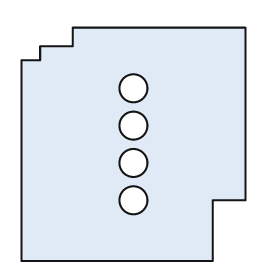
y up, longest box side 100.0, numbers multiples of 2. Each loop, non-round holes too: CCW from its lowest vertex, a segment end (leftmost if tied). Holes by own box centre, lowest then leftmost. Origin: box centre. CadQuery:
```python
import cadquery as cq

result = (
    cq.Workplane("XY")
    .moveTo(-48.0, -50.0)
    .lineTo(34.0, -50.0)
    .lineTo(34.0, -24.0)
    .lineTo(48.0, -24.0)
    .lineTo(48.0, 50.0)
    .lineTo(-26.0, 50.0)
    .lineTo(-26.0, 42.0)
    .lineTo(-40.0, 42.0)
    .lineTo(-40.0, 36.0)
    .lineTo(-48.0, 36.0)
    .close()
    .moveTo(0.0, -24.0)
    .circle(6.0)
    .moveTo(0.0, -8.0)
    .circle(6.0)
    .moveTo(0.0, 8.0)
    .circle(6.0)
    .moveTo(0.0, 24.0)
    .circle(6.0)
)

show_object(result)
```